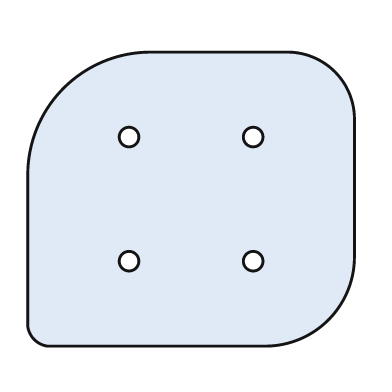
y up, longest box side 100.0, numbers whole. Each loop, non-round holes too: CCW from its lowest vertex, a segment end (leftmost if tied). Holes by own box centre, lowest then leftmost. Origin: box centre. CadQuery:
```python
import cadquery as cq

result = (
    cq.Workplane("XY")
    .moveTo(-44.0, -45.0)
    .lineTo(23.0, -45.0)
    .threePointArc((42.0, -37.0), (50.0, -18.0))
    .lineTo(50.0, 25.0)
    .threePointArc((44.0, 39.0), (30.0, 45.0))
    .lineTo(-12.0, 45.0)
    .threePointArc((-39.0, 34.0), (-50.0, 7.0))
    .lineTo(-50.0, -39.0)
    .threePointArc((-48.0, -43.0), (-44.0, -45.0))
    .close()
    .moveTo(-19.0, -19.0)
    .circle(3.0)
    .moveTo(19.0, -19.0)
    .circle(3.0)
    .moveTo(-19.0, 19.0)
    .circle(3.0)
    .moveTo(19.0, 19.0)
    .circle(3.0)
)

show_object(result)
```